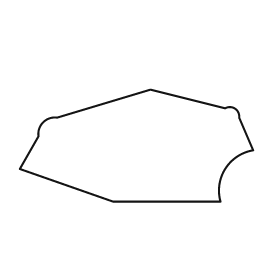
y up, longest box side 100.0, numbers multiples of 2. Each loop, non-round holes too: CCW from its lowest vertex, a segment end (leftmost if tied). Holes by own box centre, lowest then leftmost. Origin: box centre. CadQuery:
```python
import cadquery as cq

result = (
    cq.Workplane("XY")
    .moveTo(-10.0, -24.0)
    .lineTo(36.0, -24.0)
    .threePointArc((38.0, -10.0), (50.0, -2.0))
    .lineTo(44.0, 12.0)
    .threePointArc((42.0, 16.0), (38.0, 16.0))
    .lineTo(6.0, 24.0)
    .lineTo(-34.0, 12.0)
    .threePointArc((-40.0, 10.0), (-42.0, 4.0))
    .lineTo(-50.0, -10.0)
    .close()
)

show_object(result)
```